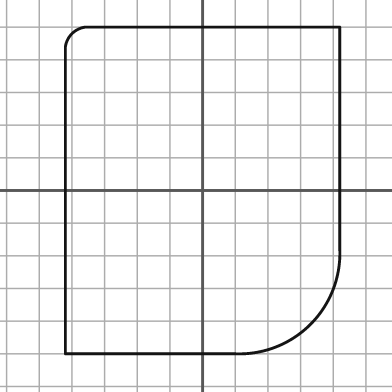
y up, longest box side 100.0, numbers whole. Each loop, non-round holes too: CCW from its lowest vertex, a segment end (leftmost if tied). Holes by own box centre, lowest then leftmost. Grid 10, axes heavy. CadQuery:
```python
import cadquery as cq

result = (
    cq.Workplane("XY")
    .moveTo(-42.0, -50.0)
    .lineTo(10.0, -50.0)
    .threePointArc((33.0, -41.0), (42.0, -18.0))
    .lineTo(42.0, 50.0)
    .lineTo(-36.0, 50.0)
    .threePointArc((-40.0, 48.0), (-42.0, 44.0))
    .close()
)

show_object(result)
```